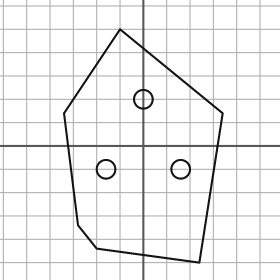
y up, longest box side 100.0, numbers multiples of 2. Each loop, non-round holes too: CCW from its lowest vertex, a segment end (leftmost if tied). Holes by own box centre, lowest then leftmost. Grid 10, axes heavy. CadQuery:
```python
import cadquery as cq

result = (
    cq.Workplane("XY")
    .moveTo(24.0, -50.0)
    .lineTo(34.0, 14.0)
    .lineTo(-10.0, 50.0)
    .lineTo(-34.0, 14.0)
    .lineTo(-28.0, -34.0)
    .lineTo(-20.0, -44.0)
    .close()
    .moveTo(-16.0, -10.0)
    .circle(4.0)
    .moveTo(16.0, -10.0)
    .circle(4.0)
    .moveTo(0.0, 20.0)
    .circle(4.0)
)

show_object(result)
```